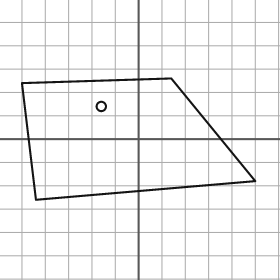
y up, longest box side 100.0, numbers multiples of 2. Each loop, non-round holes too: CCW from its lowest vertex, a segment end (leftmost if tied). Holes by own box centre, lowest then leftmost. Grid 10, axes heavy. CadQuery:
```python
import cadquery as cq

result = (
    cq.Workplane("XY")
    .moveTo(-44.0, -26.0)
    .lineTo(50.0, -18.0)
    .lineTo(14.0, 26.0)
    .lineTo(-50.0, 24.0)
    .close()
    .moveTo(-16.0, 14.0)
    .circle(2.0)
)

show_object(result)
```